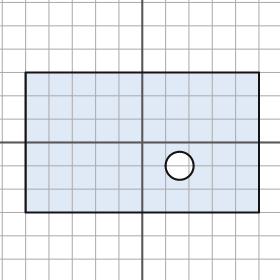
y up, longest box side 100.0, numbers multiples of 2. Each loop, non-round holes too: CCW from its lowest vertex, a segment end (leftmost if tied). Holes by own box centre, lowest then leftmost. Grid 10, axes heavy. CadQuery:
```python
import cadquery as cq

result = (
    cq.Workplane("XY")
    .moveTo(-50.0, -30.0)
    .lineTo(50.0, -30.0)
    .lineTo(50.0, 30.0)
    .lineTo(-50.0, 30.0)
    .close()
    .moveTo(16.0, -10.0)
    .circle(6.0)
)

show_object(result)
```